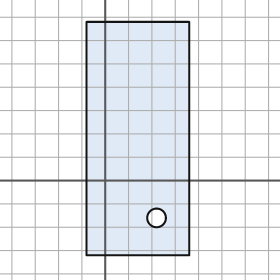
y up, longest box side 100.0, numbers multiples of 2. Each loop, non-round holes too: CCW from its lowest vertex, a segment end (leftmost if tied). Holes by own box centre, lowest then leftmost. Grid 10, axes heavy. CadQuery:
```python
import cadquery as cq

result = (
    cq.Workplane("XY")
    .moveTo(-8.0, -32.0)
    .lineTo(36.0, -32.0)
    .lineTo(36.0, 68.0)
    .lineTo(-8.0, 68.0)
    .close()
    .moveTo(22.0, -16.0)
    .circle(4.0)
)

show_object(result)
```